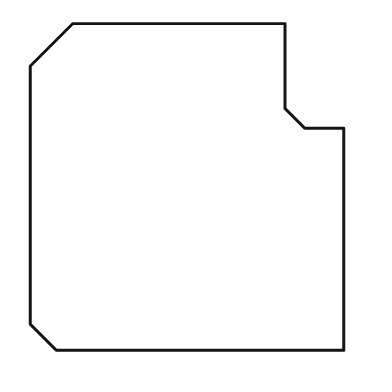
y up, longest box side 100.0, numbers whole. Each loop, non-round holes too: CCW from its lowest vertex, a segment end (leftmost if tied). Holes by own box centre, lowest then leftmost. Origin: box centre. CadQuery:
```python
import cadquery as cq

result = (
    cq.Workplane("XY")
    .moveTo(-40.0, -50.0)
    .lineTo(48.0, -50.0)
    .lineTo(48.0, 18.0)
    .lineTo(36.0, 18.0)
    .lineTo(30.0, 24.0)
    .lineTo(30.0, 50.0)
    .lineTo(-35.0, 50.0)
    .lineTo(-48.0, 37.0)
    .lineTo(-48.0, -42.0)
    .close()
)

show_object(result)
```